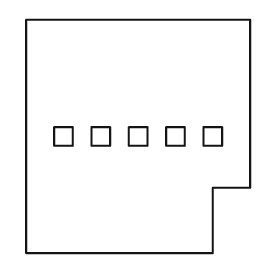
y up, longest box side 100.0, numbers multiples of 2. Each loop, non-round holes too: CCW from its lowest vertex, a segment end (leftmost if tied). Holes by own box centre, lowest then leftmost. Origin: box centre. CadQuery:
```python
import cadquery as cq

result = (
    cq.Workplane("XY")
    .moveTo(-48.0, -50.0)
    .lineTo(32.0, -50.0)
    .lineTo(32.0, -22.0)
    .lineTo(48.0, -22.0)
    .lineTo(48.0, 50.0)
    .lineTo(-48.0, 50.0)
    .close()
    .moveTo(-36.0, -4.0)
    .lineTo(-28.0, -4.0)
    .lineTo(-28.0, 4.0)
    .lineTo(-36.0, 4.0)
    .close()
    .moveTo(-20.0, -4.0)
    .lineTo(-12.0, -4.0)
    .lineTo(-12.0, 4.0)
    .lineTo(-20.0, 4.0)
    .close()
    .moveTo(-4.0, -4.0)
    .lineTo(4.0, -4.0)
    .lineTo(4.0, 4.0)
    .lineTo(-4.0, 4.0)
    .close()
    .moveTo(12.0, -4.0)
    .lineTo(20.0, -4.0)
    .lineTo(20.0, 4.0)
    .lineTo(12.0, 4.0)
    .close()
    .moveTo(28.0, -4.0)
    .lineTo(36.0, -4.0)
    .lineTo(36.0, 4.0)
    .lineTo(28.0, 4.0)
    .close()
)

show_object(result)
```